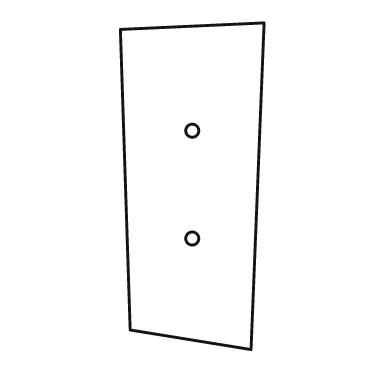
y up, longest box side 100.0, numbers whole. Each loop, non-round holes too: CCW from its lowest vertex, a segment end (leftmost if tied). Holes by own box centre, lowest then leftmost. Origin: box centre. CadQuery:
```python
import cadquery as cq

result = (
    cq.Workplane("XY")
    .moveTo(18.0, -50.0)
    .lineTo(22.0, 50.0)
    .lineTo(-22.0, 48.0)
    .lineTo(-19.0, -44.0)
    .close()
    .moveTo(0.0, -16.0)
    .circle(2.0)
    .moveTo(0.0, 17.0)
    .circle(2.0)
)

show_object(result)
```